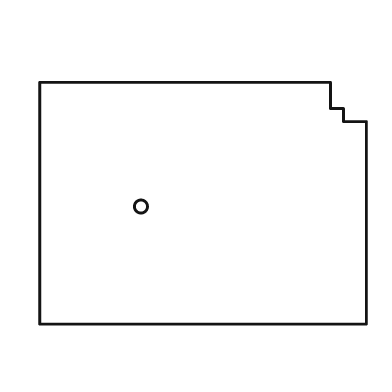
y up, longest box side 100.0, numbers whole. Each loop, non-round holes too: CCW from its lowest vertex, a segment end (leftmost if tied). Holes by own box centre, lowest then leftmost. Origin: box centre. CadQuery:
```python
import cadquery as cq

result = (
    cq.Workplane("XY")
    .moveTo(-50.0, -37.0)
    .lineTo(50.0, -37.0)
    .lineTo(50.0, 25.0)
    .lineTo(43.0, 25.0)
    .lineTo(43.0, 29.0)
    .lineTo(39.0, 29.0)
    .lineTo(39.0, 37.0)
    .lineTo(-50.0, 37.0)
    .close()
    .moveTo(-19.0, -1.0)
    .circle(2.0)
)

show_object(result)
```